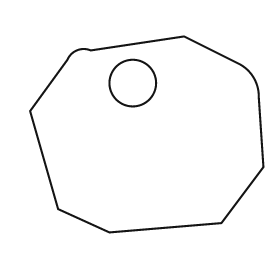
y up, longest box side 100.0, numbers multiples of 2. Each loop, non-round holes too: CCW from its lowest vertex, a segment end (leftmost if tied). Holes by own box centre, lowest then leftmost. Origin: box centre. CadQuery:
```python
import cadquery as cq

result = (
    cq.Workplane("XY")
    .moveTo(-16.0, -42.0)
    .lineTo(32.0, -38.0)
    .lineTo(50.0, -14.0)
    .lineTo(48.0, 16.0)
    .threePointArc((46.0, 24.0), (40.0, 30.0))
    .lineTo(16.0, 42.0)
    .lineTo(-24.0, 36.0)
    .threePointArc((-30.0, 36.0), (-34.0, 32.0))
    .lineTo(-50.0, 10.0)
    .lineTo(-38.0, -32.0)
    .close()
    .moveTo(-6.0, 22.0)
    .circle(10.0)
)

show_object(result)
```